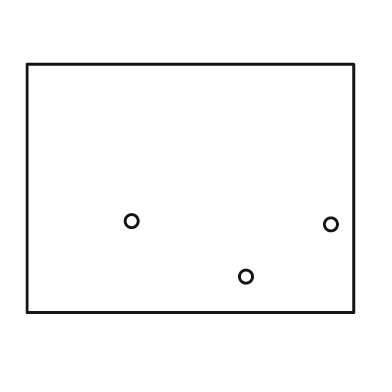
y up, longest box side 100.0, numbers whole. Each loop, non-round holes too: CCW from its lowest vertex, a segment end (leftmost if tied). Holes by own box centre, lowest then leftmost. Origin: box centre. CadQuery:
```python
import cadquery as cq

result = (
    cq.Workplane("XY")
    .moveTo(-50.0, -38.0)
    .lineTo(50.0, -38.0)
    .lineTo(50.0, 38.0)
    .lineTo(-50.0, 38.0)
    .close()
    .moveTo(17.0, -27.0)
    .circle(2.0)
    .moveTo(43.0, -11.0)
    .circle(2.0)
    .moveTo(-18.0, -10.0)
    .circle(2.0)
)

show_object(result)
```